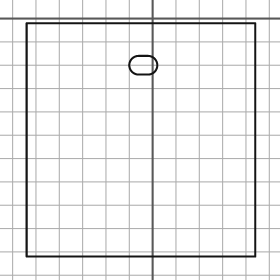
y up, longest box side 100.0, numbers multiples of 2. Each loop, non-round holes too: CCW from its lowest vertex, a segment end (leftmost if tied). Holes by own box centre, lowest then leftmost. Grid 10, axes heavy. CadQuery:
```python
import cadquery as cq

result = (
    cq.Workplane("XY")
    .moveTo(-54.0, -102.0)
    .lineTo(44.0, -102.0)
    .lineTo(44.0, -2.0)
    .lineTo(-54.0, -2.0)
    .close()
    .moveTo(-6.0, -24.0)
    .lineTo(-2.0, -24.0)
    .threePointArc((2.0, -20.0), (-2.0, -16.0))
    .lineTo(-6.0, -16.0)
    .threePointArc((-10.0, -20.0), (-6.0, -24.0))
    .close()
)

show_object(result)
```